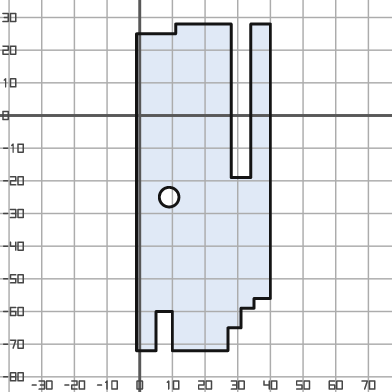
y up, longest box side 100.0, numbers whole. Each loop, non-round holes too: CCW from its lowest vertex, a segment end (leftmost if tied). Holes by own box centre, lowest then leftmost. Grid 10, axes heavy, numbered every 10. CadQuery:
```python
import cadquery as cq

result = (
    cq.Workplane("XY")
    .moveTo(-1.0, -72.0)
    .lineTo(5.0, -72.0)
    .lineTo(5.0, -60.0)
    .lineTo(10.0, -60.0)
    .lineTo(10.0, -72.0)
    .lineTo(27.0, -72.0)
    .lineTo(27.0, -65.0)
    .lineTo(31.0, -65.0)
    .lineTo(31.0, -59.0)
    .lineTo(35.0, -59.0)
    .lineTo(35.0, -56.0)
    .lineTo(40.0, -56.0)
    .lineTo(40.0, 28.0)
    .lineTo(34.0, 28.0)
    .lineTo(34.0, -19.0)
    .lineTo(28.0, -19.0)
    .lineTo(28.0, 28.0)
    .lineTo(11.0, 28.0)
    .lineTo(11.0, 25.0)
    .lineTo(-1.0, 25.0)
    .close()
    .moveTo(9.0, -25.0)
    .circle(3.0)
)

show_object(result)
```